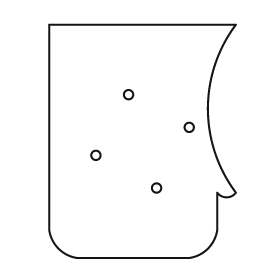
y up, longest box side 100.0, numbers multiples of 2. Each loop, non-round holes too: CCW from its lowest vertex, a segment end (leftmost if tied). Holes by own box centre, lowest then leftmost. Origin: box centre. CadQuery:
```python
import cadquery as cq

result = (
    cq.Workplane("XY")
    .moveTo(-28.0, -50.0)
    .lineTo(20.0, -50.0)
    .threePointArc((28.0, -46.0), (32.0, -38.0))
    .lineTo(32.0, -22.0)
    .threePointArc((36.0, -24.0), (40.0, -22.0))
    .threePointArc((28.0, 14.0), (40.0, 50.0))
    .lineTo(-40.0, 50.0)
    .lineTo(-40.0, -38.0)
    .threePointArc((-36.0, -46.0), (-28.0, -50.0))
    .close()
    .moveTo(6.0, -20.0)
    .circle(2.0)
    .moveTo(-20.0, -6.0)
    .circle(2.0)
    .moveTo(20.0, 6.0)
    .circle(2.0)
    .moveTo(-6.0, 20.0)
    .circle(2.0)
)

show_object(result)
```